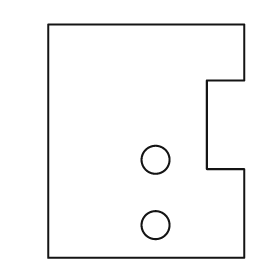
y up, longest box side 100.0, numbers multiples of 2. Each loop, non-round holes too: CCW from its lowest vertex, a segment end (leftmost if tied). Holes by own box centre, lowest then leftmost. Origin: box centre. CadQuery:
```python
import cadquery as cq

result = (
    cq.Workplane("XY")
    .moveTo(-42.0, -50.0)
    .lineTo(42.0, -50.0)
    .lineTo(42.0, -12.0)
    .lineTo(26.0, -12.0)
    .lineTo(26.0, 26.0)
    .lineTo(42.0, 26.0)
    .lineTo(42.0, 50.0)
    .lineTo(-42.0, 50.0)
    .close()
    .moveTo(4.0, -36.0)
    .circle(6.0)
    .moveTo(4.0, -8.0)
    .circle(6.0)
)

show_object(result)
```